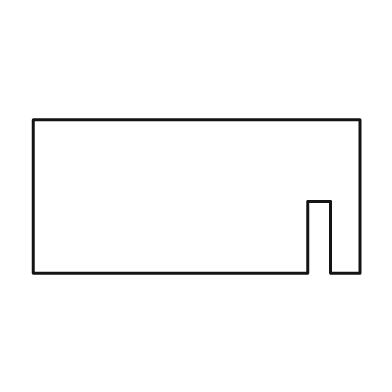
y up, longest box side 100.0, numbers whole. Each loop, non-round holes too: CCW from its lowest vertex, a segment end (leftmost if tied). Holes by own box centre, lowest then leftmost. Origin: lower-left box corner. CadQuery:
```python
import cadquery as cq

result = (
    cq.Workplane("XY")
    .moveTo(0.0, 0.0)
    .lineTo(84.0, 0.0)
    .lineTo(84.0, 22.0)
    .lineTo(91.0, 22.0)
    .lineTo(91.0, 0.0)
    .lineTo(100.0, 0.0)
    .lineTo(100.0, 47.0)
    .lineTo(0.0, 47.0)
    .close()
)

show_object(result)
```